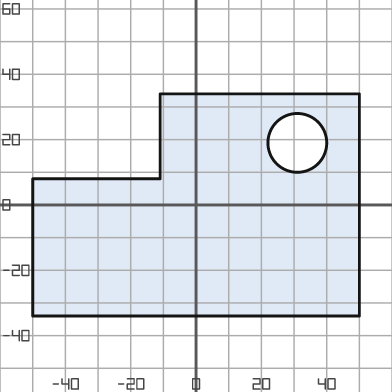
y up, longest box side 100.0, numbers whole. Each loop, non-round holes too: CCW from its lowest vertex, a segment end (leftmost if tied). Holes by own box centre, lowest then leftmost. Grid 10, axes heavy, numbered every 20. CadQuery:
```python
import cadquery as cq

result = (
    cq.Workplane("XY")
    .moveTo(-50.0, -34.0)
    .lineTo(50.0, -34.0)
    .lineTo(50.0, 34.0)
    .lineTo(-11.0, 34.0)
    .lineTo(-11.0, 8.0)
    .lineTo(-50.0, 8.0)
    .close()
    .moveTo(31.0, 19.0)
    .circle(9.0)
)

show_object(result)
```